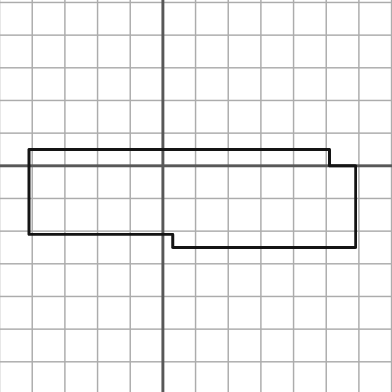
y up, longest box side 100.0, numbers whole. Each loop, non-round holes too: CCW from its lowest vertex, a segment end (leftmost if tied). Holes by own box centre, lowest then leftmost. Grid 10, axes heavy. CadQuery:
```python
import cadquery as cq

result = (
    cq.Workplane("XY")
    .moveTo(3.0, -25.0)
    .lineTo(59.0, -25.0)
    .lineTo(59.0, 0.0)
    .lineTo(51.0, 0.0)
    .lineTo(51.0, 5.0)
    .lineTo(-41.0, 5.0)
    .lineTo(-41.0, -21.0)
    .lineTo(3.0, -21.0)
    .close()
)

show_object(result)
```